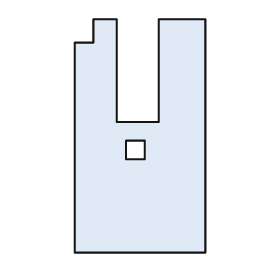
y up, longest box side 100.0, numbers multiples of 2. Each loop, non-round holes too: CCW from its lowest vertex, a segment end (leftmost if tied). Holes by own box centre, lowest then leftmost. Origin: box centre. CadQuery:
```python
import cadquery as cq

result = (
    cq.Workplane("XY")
    .moveTo(-28.0, -50.0)
    .lineTo(28.0, -50.0)
    .lineTo(28.0, 50.0)
    .lineTo(8.0, 50.0)
    .lineTo(8.0, 6.0)
    .lineTo(-10.0, 6.0)
    .lineTo(-10.0, 50.0)
    .lineTo(-20.0, 50.0)
    .lineTo(-20.0, 40.0)
    .lineTo(-28.0, 40.0)
    .close()
    .moveTo(-6.0, -10.0)
    .lineTo(2.0, -10.0)
    .lineTo(2.0, -2.0)
    .lineTo(-6.0, -2.0)
    .close()
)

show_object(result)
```